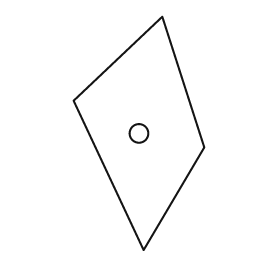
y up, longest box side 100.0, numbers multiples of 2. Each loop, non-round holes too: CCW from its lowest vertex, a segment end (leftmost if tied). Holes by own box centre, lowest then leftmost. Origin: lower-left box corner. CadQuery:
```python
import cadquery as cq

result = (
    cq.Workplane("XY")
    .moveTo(30.0, 0.0)
    .lineTo(56.0, 44.0)
    .lineTo(38.0, 100.0)
    .lineTo(0.0, 64.0)
    .close()
    .moveTo(28.0, 50.0)
    .circle(4.0)
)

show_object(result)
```